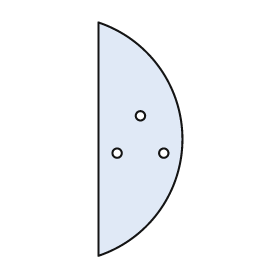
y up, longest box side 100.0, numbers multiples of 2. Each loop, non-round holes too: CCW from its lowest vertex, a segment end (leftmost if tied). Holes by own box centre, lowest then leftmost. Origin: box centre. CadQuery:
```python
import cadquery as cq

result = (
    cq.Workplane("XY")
    .moveTo(-18.0, -50.0)
    .threePointArc((18.0, 0.0), (-18.0, 50.0))
    .close()
    .moveTo(-10.0, -6.0)
    .circle(2.0)
    .moveTo(10.0, -6.0)
    .circle(2.0)
    .moveTo(0.0, 10.0)
    .circle(2.0)
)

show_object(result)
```